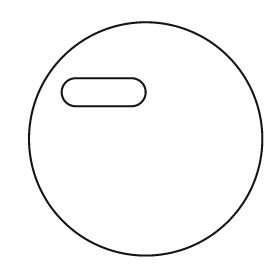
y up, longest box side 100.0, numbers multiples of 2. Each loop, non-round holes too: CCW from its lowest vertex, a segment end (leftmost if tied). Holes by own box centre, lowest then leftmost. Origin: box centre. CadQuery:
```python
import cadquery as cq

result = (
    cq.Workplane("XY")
    .moveTo(0.0, 0.0)
    .circle(50.0)
    .moveTo(-30.0, 14.0)
    .lineTo(-6.0, 14.0)
    .threePointArc((0.0, 20.0), (-6.0, 26.0))
    .lineTo(-30.0, 26.0)
    .threePointArc((-36.0, 20.0), (-30.0, 14.0))
    .close()
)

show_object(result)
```